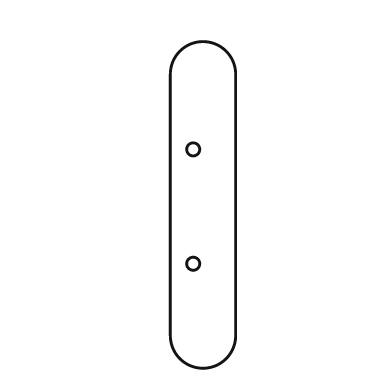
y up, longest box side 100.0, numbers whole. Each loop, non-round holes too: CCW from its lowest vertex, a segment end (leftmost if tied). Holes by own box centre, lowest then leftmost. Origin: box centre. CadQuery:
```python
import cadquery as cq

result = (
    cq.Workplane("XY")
    .moveTo(-10.0, -40.0)
    .threePointArc((0.0, -50.0), (10.0, -40.0))
    .lineTo(10.0, 40.0)
    .threePointArc((0.0, 50.0), (-10.0, 40.0))
    .close()
    .moveTo(-3.0, -18.0)
    .circle(2.0)
    .moveTo(-3.0, 17.0)
    .circle(2.0)
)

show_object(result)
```